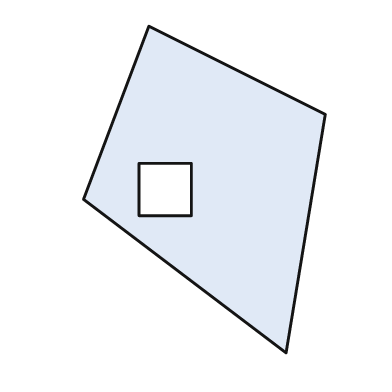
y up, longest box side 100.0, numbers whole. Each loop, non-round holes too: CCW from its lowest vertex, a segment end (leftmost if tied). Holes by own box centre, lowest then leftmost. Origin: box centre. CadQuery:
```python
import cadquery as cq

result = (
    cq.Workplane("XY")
    .moveTo(25.0, -50.0)
    .lineTo(37.0, 23.0)
    .lineTo(-17.0, 50.0)
    .lineTo(-37.0, -3.0)
    .close()
    .moveTo(-20.0, -8.0)
    .lineTo(-4.0, -8.0)
    .lineTo(-4.0, 8.0)
    .lineTo(-20.0, 8.0)
    .close()
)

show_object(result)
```